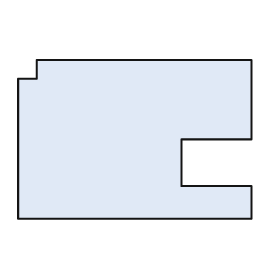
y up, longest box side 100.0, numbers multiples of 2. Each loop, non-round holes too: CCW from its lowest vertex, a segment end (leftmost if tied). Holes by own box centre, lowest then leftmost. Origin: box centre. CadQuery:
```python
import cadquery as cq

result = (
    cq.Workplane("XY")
    .moveTo(-50.0, -34.0)
    .lineTo(50.0, -34.0)
    .lineTo(50.0, -20.0)
    .lineTo(20.0, -20.0)
    .lineTo(20.0, 0.0)
    .lineTo(50.0, 0.0)
    .lineTo(50.0, 34.0)
    .lineTo(-42.0, 34.0)
    .lineTo(-42.0, 26.0)
    .lineTo(-50.0, 26.0)
    .close()
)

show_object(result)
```